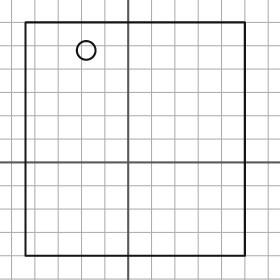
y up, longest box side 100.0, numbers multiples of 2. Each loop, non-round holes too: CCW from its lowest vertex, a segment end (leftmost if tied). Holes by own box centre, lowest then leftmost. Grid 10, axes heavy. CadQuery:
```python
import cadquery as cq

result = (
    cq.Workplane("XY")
    .moveTo(-44.0, -40.0)
    .lineTo(50.0, -40.0)
    .lineTo(50.0, 60.0)
    .lineTo(-44.0, 60.0)
    .close()
    .moveTo(-18.0, 48.0)
    .circle(4.0)
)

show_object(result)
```